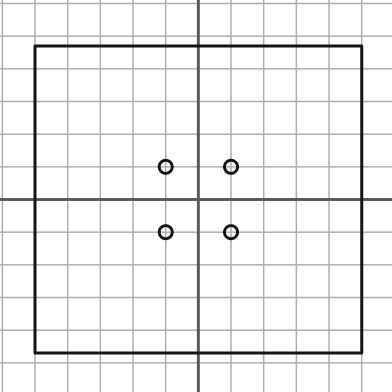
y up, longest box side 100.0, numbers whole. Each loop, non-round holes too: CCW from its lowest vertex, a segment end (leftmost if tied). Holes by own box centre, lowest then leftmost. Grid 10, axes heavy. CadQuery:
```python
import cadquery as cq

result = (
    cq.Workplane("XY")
    .moveTo(-50.0, -47.0)
    .lineTo(50.0, -47.0)
    .lineTo(50.0, 47.0)
    .lineTo(-50.0, 47.0)
    .close()
    .moveTo(-10.0, -10.0)
    .circle(2.0)
    .moveTo(10.0, -10.0)
    .circle(2.0)
    .moveTo(-10.0, 10.0)
    .circle(2.0)
    .moveTo(10.0, 10.0)
    .circle(2.0)
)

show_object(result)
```